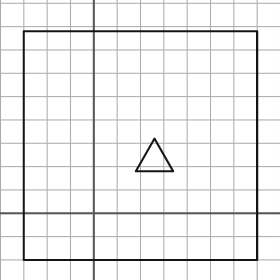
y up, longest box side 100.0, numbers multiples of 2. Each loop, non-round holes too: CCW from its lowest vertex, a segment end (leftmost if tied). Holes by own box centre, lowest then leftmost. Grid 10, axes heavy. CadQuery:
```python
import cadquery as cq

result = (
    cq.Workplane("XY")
    .moveTo(-30.0, -20.0)
    .lineTo(70.0, -20.0)
    .lineTo(70.0, 78.0)
    .lineTo(-30.0, 78.0)
    .close()
    .moveTo(18.0, 18.0)
    .lineTo(34.0, 18.0)
    .lineTo(26.0, 32.0)
    .close()
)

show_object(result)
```